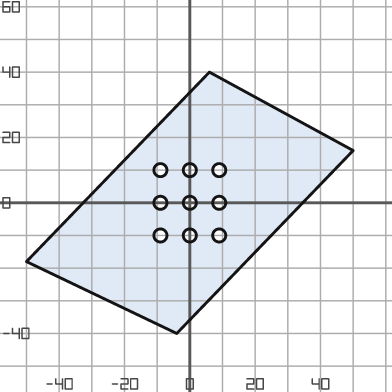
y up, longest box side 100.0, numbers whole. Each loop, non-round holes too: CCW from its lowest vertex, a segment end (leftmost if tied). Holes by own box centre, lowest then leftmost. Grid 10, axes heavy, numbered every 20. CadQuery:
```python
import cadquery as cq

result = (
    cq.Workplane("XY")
    .moveTo(-4.0, -40.0)
    .lineTo(50.0, 16.0)
    .lineTo(6.0, 40.0)
    .lineTo(-50.0, -18.0)
    .close()
    .moveTo(-9.0, -10.0)
    .circle(2.0)
    .moveTo(0.0, -10.0)
    .circle(2.0)
    .moveTo(9.0, -10.0)
    .circle(2.0)
    .moveTo(-9.0, 0.0)
    .circle(2.0)
    .moveTo(0.0, 0.0)
    .circle(2.0)
    .moveTo(9.0, 0.0)
    .circle(2.0)
    .moveTo(-9.0, 10.0)
    .circle(2.0)
    .moveTo(0.0, 10.0)
    .circle(2.0)
    .moveTo(9.0, 10.0)
    .circle(2.0)
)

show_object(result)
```